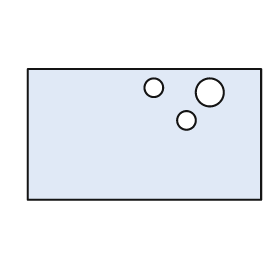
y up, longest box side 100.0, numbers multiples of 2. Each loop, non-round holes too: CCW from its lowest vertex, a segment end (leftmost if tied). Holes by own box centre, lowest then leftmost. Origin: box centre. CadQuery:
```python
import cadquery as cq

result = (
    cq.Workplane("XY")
    .moveTo(-50.0, -28.0)
    .lineTo(50.0, -28.0)
    .lineTo(50.0, 28.0)
    .lineTo(-50.0, 28.0)
    .close()
    .moveTo(18.0, 6.0)
    .circle(4.0)
    .moveTo(28.0, 18.0)
    .circle(6.0)
    .moveTo(4.0, 20.0)
    .circle(4.0)
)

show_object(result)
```